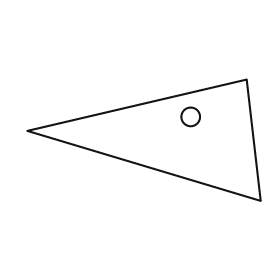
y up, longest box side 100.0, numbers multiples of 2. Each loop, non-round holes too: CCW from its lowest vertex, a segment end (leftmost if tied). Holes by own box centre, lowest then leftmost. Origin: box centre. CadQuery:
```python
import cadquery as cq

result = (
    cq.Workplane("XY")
    .moveTo(50.0, -26.0)
    .lineTo(44.0, 26.0)
    .lineTo(-50.0, 4.0)
    .close()
    .moveTo(20.0, 10.0)
    .circle(4.0)
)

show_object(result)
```